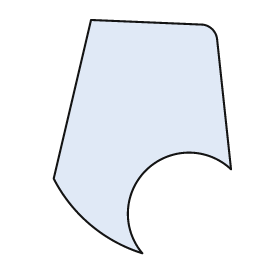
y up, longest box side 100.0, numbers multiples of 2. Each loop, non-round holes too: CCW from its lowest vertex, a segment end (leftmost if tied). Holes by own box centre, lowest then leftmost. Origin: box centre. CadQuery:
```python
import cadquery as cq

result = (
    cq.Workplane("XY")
    .moveTo(0.0, -50.0)
    .threePointArc((2.0, -14.0), (38.0, -14.0))
    .lineTo(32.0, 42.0)
    .threePointArc((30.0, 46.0), (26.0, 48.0))
    .lineTo(-22.0, 50.0)
    .lineTo(-38.0, -18.0)
    .threePointArc((-22.0, -38.0), (0.0, -50.0))
    .close()
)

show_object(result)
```